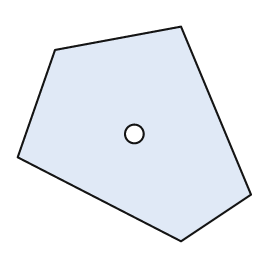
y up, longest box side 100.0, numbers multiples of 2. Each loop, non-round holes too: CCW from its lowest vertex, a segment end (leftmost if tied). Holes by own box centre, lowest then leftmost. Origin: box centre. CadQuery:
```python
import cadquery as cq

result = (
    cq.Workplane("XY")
    .moveTo(20.0, -46.0)
    .lineTo(50.0, -26.0)
    .lineTo(20.0, 46.0)
    .lineTo(-34.0, 36.0)
    .lineTo(-50.0, -10.0)
    .close()
    .moveTo(0.0, 0.0)
    .circle(4.0)
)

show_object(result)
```